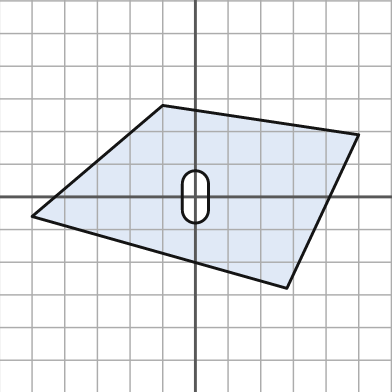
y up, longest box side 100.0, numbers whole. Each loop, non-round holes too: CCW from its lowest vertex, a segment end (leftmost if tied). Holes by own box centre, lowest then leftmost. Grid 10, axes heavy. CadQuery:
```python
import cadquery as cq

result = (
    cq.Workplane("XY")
    .moveTo(28.0, -28.0)
    .lineTo(50.0, 19.0)
    .lineTo(-10.0, 28.0)
    .lineTo(-50.0, -6.0)
    .close()
    .moveTo(-4.0, -4.0)
    .threePointArc((0.0, -8.0), (4.0, -4.0))
    .lineTo(4.0, 4.0)
    .threePointArc((0.0, 8.0), (-4.0, 4.0))
    .close()
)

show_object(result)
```